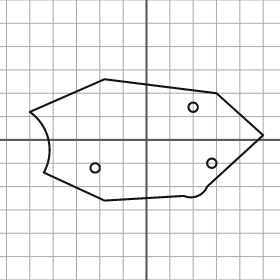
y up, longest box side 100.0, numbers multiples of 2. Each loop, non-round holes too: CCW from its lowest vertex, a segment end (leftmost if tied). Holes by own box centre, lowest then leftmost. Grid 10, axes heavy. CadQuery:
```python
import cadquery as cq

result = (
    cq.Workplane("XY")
    .moveTo(-18.0, -26.0)
    .lineTo(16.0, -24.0)
    .threePointArc((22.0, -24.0), (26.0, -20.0))
    .lineTo(50.0, 2.0)
    .lineTo(30.0, 20.0)
    .lineTo(-18.0, 26.0)
    .lineTo(-50.0, 12.0)
    .threePointArc((-42.0, 0.0), (-44.0, -14.0))
    .close()
    .moveTo(-22.0, -12.0)
    .circle(2.0)
    .moveTo(28.0, -10.0)
    .circle(2.0)
    .moveTo(20.0, 14.0)
    .circle(2.0)
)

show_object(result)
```